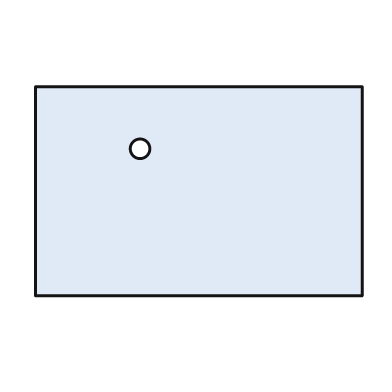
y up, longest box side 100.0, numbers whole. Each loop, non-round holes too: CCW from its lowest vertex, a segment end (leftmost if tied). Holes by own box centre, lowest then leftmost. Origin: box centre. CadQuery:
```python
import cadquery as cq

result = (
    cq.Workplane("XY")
    .moveTo(-50.0, -32.0)
    .lineTo(50.0, -32.0)
    .lineTo(50.0, 32.0)
    .lineTo(-50.0, 32.0)
    .close()
    .moveTo(-18.0, 13.0)
    .circle(3.0)
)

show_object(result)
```